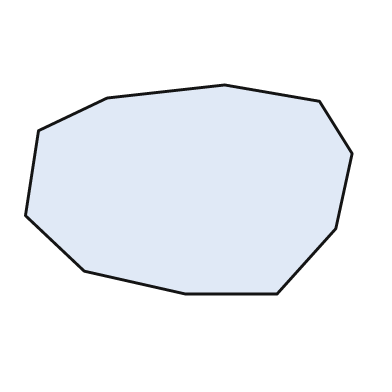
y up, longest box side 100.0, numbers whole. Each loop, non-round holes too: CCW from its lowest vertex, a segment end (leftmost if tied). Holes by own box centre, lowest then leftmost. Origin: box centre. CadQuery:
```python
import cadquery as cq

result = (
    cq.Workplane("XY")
    .moveTo(-1.0, -32.0)
    .lineTo(27.0, -32.0)
    .lineTo(45.0, -12.0)
    .lineTo(50.0, 11.0)
    .lineTo(40.0, 27.0)
    .lineTo(11.0, 32.0)
    .lineTo(-25.0, 28.0)
    .lineTo(-46.0, 18.0)
    .lineTo(-50.0, -8.0)
    .lineTo(-32.0, -25.0)
    .close()
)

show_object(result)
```